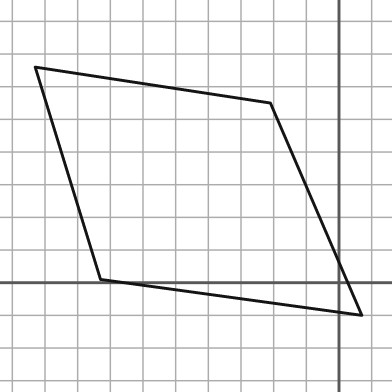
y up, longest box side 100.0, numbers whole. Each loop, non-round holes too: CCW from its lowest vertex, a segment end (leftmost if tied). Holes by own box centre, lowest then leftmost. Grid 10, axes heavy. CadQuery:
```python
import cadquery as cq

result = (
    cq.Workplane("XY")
    .moveTo(7.0, -10.0)
    .lineTo(-21.0, 55.0)
    .lineTo(-93.0, 66.0)
    .lineTo(-73.0, 1.0)
    .close()
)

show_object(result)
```